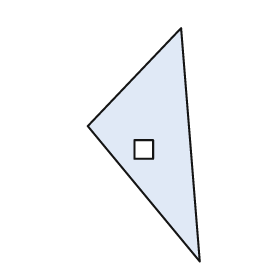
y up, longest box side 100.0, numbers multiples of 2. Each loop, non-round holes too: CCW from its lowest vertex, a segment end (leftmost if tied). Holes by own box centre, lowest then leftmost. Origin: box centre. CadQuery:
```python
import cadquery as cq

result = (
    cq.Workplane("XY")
    .moveTo(24.0, -50.0)
    .lineTo(16.0, 50.0)
    .lineTo(-24.0, 8.0)
    .close()
    .moveTo(-4.0, -6.0)
    .lineTo(4.0, -6.0)
    .lineTo(4.0, 2.0)
    .lineTo(-4.0, 2.0)
    .close()
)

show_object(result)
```